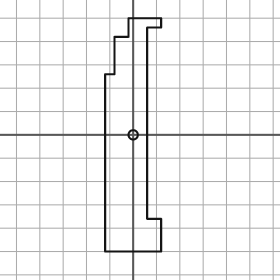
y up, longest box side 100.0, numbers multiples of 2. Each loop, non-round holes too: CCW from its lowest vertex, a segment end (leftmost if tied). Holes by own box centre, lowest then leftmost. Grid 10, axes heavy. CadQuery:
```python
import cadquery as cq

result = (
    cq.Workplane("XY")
    .moveTo(-12.0, -50.0)
    .lineTo(12.0, -50.0)
    .lineTo(12.0, -36.0)
    .lineTo(6.0, -36.0)
    .lineTo(6.0, 46.0)
    .lineTo(12.0, 46.0)
    .lineTo(12.0, 50.0)
    .lineTo(-2.0, 50.0)
    .lineTo(-2.0, 42.0)
    .lineTo(-8.0, 42.0)
    .lineTo(-8.0, 26.0)
    .lineTo(-12.0, 26.0)
    .close()
    .moveTo(0.0, 0.0)
    .circle(2.0)
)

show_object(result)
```